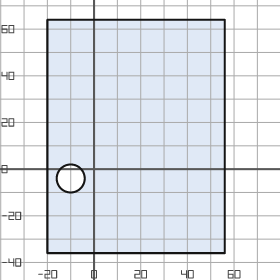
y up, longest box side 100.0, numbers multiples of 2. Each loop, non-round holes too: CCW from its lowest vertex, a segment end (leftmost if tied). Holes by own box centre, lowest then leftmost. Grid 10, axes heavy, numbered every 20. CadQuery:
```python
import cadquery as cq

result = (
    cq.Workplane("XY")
    .moveTo(-20.0, -36.0)
    .lineTo(56.0, -36.0)
    .lineTo(56.0, 64.0)
    .lineTo(-20.0, 64.0)
    .close()
    .moveTo(-10.0, -4.0)
    .circle(6.0)
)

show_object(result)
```